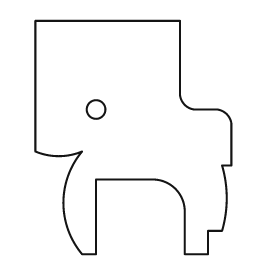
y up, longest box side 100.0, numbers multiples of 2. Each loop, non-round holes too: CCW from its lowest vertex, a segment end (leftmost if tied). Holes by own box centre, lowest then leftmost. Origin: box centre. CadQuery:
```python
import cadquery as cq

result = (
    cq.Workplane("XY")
    .moveTo(-22.0, -50.0)
    .lineTo(-16.0, -50.0)
    .lineTo(-16.0, -18.0)
    .lineTo(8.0, -18.0)
    .threePointArc((18.0, -22.0), (22.0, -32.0))
    .lineTo(22.0, -50.0)
    .lineTo(32.0, -50.0)
    .lineTo(32.0, -40.0)
    .lineTo(38.0, -40.0)
    .threePointArc((40.0, -26.0), (38.0, -12.0))
    .lineTo(42.0, -12.0)
    .lineTo(42.0, 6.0)
    .threePointArc((40.0, 10.0), (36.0, 12.0))
    .lineTo(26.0, 12.0)
    .threePointArc((22.0, 14.0), (20.0, 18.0))
    .lineTo(20.0, 50.0)
    .lineTo(-42.0, 50.0)
    .lineTo(-42.0, -6.0)
    .threePointArc((-32.0, -8.0), (-22.0, -6.0))
    .threePointArc((-30.0, -28.0), (-22.0, -50.0))
    .close()
    .moveTo(-16.0, 12.0)
    .circle(4.0)
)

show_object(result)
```